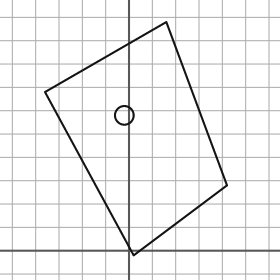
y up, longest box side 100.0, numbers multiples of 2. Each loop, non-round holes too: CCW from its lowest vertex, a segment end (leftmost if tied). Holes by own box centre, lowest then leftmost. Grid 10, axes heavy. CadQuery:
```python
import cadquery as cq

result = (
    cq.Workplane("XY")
    .moveTo(2.0, -2.0)
    .lineTo(42.0, 28.0)
    .lineTo(16.0, 98.0)
    .lineTo(-36.0, 68.0)
    .close()
    .moveTo(-2.0, 58.0)
    .circle(4.0)
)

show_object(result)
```